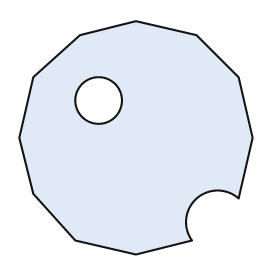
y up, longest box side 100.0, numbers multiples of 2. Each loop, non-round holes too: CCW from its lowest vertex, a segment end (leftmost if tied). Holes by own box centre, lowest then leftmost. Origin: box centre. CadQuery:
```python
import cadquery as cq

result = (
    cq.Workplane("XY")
    .moveTo(0.0, -50.0)
    .lineTo(24.0, -44.0)
    .threePointArc((26.0, -26.0), (44.0, -26.0))
    .lineTo(50.0, 0.0)
    .lineTo(44.0, 26.0)
    .lineTo(26.0, 44.0)
    .lineTo(0.0, 50.0)
    .lineTo(-24.0, 44.0)
    .lineTo(-44.0, 26.0)
    .lineTo(-50.0, 0.0)
    .lineTo(-44.0, -24.0)
    .lineTo(-26.0, -44.0)
    .close()
    .moveTo(-16.0, 16.0)
    .circle(10.0)
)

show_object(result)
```